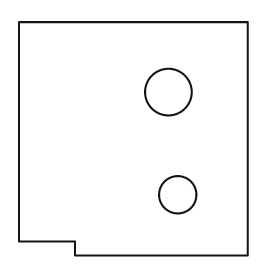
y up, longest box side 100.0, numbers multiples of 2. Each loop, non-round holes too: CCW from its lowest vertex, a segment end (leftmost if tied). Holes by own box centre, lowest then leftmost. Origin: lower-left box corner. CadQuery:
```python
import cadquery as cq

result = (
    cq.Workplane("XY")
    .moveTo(24.0, 0.0)
    .lineTo(98.0, 0.0)
    .lineTo(98.0, 100.0)
    .lineTo(0.0, 100.0)
    .lineTo(0.0, 6.0)
    .lineTo(24.0, 6.0)
    .close()
    .moveTo(68.0, 26.0)
    .circle(8.0)
    .moveTo(64.0, 70.0)
    .circle(10.0)
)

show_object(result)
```